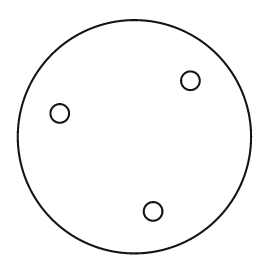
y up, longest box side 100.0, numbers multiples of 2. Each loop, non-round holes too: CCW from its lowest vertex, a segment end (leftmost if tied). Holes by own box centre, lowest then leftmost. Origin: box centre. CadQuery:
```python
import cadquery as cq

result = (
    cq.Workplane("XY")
    .moveTo(0.0, 0.0)
    .circle(50.0)
    .moveTo(8.0, -32.0)
    .circle(4.0)
    .moveTo(-32.0, 10.0)
    .circle(4.0)
    .moveTo(24.0, 24.0)
    .circle(4.0)
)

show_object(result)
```